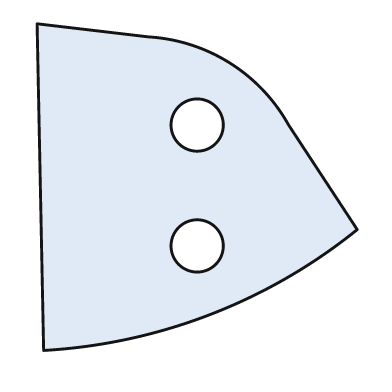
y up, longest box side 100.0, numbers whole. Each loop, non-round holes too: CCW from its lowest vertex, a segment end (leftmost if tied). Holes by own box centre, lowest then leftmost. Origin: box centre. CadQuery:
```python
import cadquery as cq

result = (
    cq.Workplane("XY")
    .moveTo(-47.0, -50.0)
    .threePointArc((4.0, -39.0), (49.0, -13.0))
    .lineTo(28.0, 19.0)
    .threePointArc((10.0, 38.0), (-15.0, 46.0))
    .lineTo(-49.0, 50.0)
    .close()
    .moveTo(0.0, -18.0)
    .circle(8.0)
    .moveTo(0.0, 19.0)
    .circle(8.0)
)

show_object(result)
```